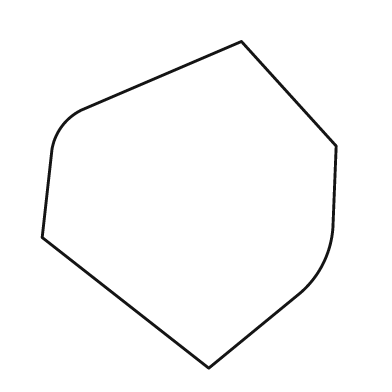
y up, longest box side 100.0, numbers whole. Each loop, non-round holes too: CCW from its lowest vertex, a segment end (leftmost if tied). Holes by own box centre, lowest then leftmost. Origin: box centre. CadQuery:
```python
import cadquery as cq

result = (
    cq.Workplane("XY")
    .moveTo(6.0, -50.0)
    .lineTo(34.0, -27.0)
    .threePointArc((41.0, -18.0), (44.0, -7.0))
    .lineTo(45.0, 18.0)
    .lineTo(16.0, 50.0)
    .lineTo(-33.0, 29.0)
    .threePointArc((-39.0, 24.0), (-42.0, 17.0))
    .lineTo(-45.0, -10.0)
    .close()
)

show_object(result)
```